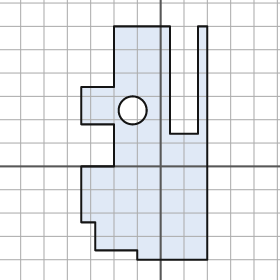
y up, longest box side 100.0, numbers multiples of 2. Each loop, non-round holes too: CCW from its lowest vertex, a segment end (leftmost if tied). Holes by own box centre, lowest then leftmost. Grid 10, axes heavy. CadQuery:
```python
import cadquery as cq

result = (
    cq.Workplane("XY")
    .moveTo(-10.0, -40.0)
    .lineTo(20.0, -40.0)
    .lineTo(20.0, 60.0)
    .lineTo(16.0, 60.0)
    .lineTo(16.0, 14.0)
    .lineTo(4.0, 14.0)
    .lineTo(4.0, 60.0)
    .lineTo(-20.0, 60.0)
    .lineTo(-20.0, 34.0)
    .lineTo(-34.0, 34.0)
    .lineTo(-34.0, 18.0)
    .lineTo(-20.0, 18.0)
    .lineTo(-20.0, 0.0)
    .lineTo(-34.0, 0.0)
    .lineTo(-34.0, -24.0)
    .lineTo(-28.0, -24.0)
    .lineTo(-28.0, -36.0)
    .lineTo(-10.0, -36.0)
    .close()
    .moveTo(-12.0, 24.0)
    .circle(6.0)
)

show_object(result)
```